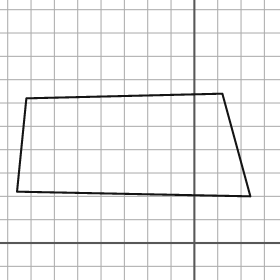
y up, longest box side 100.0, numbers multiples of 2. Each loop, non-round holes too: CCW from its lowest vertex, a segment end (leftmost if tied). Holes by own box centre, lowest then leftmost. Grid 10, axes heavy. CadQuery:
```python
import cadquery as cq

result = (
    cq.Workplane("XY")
    .moveTo(24.0, 20.0)
    .lineTo(12.0, 64.0)
    .lineTo(-72.0, 62.0)
    .lineTo(-76.0, 22.0)
    .close()
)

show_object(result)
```